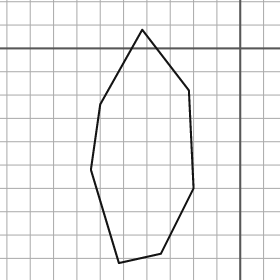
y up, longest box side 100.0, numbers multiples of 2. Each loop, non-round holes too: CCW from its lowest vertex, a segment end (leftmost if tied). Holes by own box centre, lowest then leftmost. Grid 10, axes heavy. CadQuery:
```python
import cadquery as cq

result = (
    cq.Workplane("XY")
    .moveTo(-52.0, -92.0)
    .lineTo(-34.0, -88.0)
    .lineTo(-20.0, -60.0)
    .lineTo(-22.0, -18.0)
    .lineTo(-42.0, 8.0)
    .lineTo(-60.0, -24.0)
    .lineTo(-64.0, -52.0)
    .close()
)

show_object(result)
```